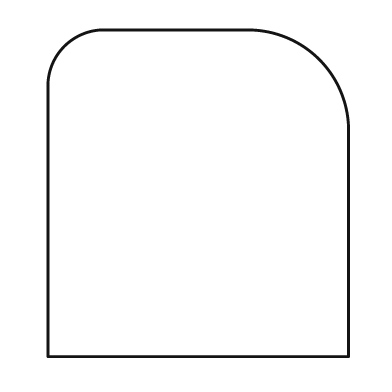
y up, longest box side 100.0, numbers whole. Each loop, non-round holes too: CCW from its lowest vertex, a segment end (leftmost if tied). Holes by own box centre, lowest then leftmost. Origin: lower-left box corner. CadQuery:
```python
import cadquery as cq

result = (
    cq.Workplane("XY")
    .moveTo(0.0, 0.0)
    .lineTo(92.0, 0.0)
    .lineTo(92.0, 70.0)
    .threePointArc((83.0, 91.0), (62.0, 100.0))
    .lineTo(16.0, 100.0)
    .threePointArc((5.0, 95.0), (0.0, 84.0))
    .close()
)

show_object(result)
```